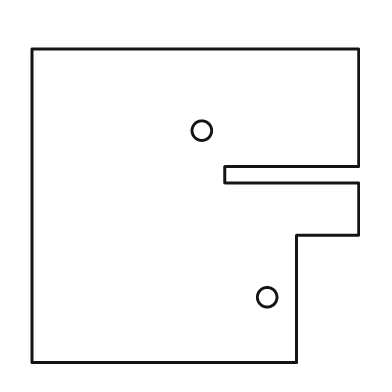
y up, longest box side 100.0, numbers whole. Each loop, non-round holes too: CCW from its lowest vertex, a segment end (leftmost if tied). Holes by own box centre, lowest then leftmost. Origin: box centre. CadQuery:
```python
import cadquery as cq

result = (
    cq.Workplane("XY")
    .moveTo(-50.0, -48.0)
    .lineTo(31.0, -48.0)
    .lineTo(31.0, -9.0)
    .lineTo(50.0, -9.0)
    .lineTo(50.0, 7.0)
    .lineTo(9.0, 7.0)
    .lineTo(9.0, 12.0)
    .lineTo(50.0, 12.0)
    .lineTo(50.0, 48.0)
    .lineTo(-50.0, 48.0)
    .close()
    .moveTo(22.0, -28.0)
    .circle(3.0)
    .moveTo(2.0, 23.0)
    .circle(3.0)
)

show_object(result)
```